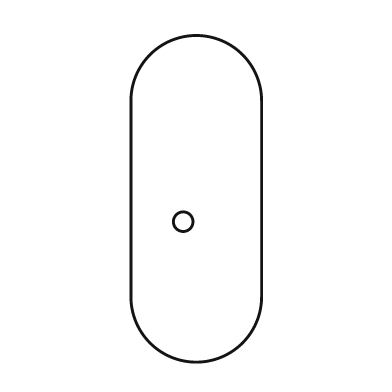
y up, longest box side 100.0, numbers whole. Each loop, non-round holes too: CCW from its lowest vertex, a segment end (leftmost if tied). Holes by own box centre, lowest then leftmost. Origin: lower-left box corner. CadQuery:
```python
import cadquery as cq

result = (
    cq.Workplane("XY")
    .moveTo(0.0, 20.0)
    .threePointArc((20.0, 0.0), (40.0, 20.0))
    .lineTo(40.0, 80.0)
    .threePointArc((20.0, 100.0), (0.0, 80.0))
    .close()
    .moveTo(16.0, 43.0)
    .circle(3.0)
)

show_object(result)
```